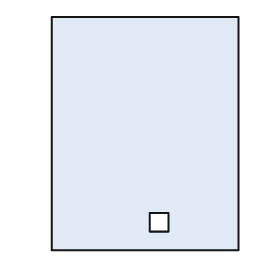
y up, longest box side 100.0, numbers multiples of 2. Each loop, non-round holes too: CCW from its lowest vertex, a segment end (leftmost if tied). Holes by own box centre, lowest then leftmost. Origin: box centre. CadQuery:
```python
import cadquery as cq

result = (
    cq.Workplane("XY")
    .moveTo(-40.0, -50.0)
    .lineTo(40.0, -50.0)
    .lineTo(40.0, 50.0)
    .lineTo(-40.0, 50.0)
    .close()
    .moveTo(2.0, -42.0)
    .lineTo(10.0, -42.0)
    .lineTo(10.0, -34.0)
    .lineTo(2.0, -34.0)
    .close()
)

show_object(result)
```